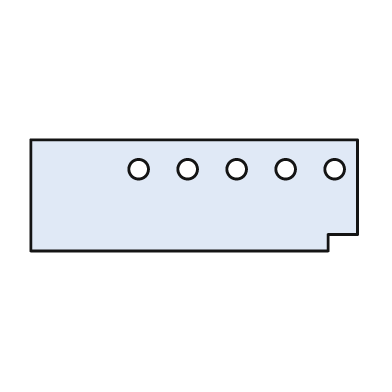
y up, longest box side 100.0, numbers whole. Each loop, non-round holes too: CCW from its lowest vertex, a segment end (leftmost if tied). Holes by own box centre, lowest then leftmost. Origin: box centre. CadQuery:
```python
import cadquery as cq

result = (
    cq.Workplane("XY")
    .moveTo(-50.0, -17.0)
    .lineTo(41.0, -17.0)
    .lineTo(41.0, -12.0)
    .lineTo(50.0, -12.0)
    .lineTo(50.0, 17.0)
    .lineTo(-50.0, 17.0)
    .close()
    .moveTo(-17.0, 8.0)
    .circle(3.0)
    .moveTo(-2.0, 8.0)
    .circle(3.0)
    .moveTo(13.0, 8.0)
    .circle(3.0)
    .moveTo(28.0, 8.0)
    .circle(3.0)
    .moveTo(43.0, 8.0)
    .circle(3.0)
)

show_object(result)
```